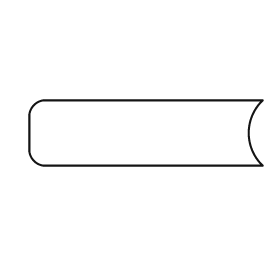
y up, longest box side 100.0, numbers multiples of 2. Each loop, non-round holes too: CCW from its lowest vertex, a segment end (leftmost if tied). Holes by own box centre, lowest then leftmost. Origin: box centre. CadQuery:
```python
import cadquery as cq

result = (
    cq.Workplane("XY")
    .moveTo(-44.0, -14.0)
    .lineTo(50.0, -14.0)
    .threePointArc((44.0, 0.0), (50.0, 14.0))
    .lineTo(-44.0, 14.0)
    .threePointArc((-48.0, 12.0), (-50.0, 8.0))
    .lineTo(-50.0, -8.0)
    .threePointArc((-48.0, -12.0), (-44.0, -14.0))
    .close()
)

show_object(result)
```